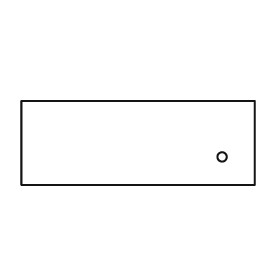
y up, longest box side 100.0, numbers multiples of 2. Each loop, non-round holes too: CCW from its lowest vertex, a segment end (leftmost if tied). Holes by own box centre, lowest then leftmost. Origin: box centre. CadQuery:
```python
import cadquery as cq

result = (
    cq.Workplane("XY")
    .moveTo(-50.0, -18.0)
    .lineTo(50.0, -18.0)
    .lineTo(50.0, 18.0)
    .lineTo(-50.0, 18.0)
    .close()
    .moveTo(36.0, -6.0)
    .circle(2.0)
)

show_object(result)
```